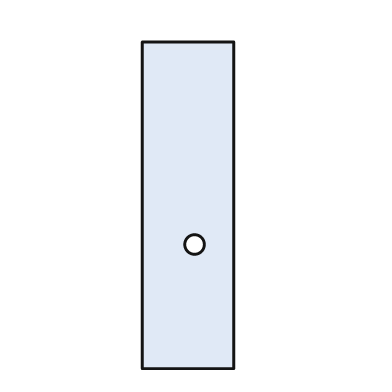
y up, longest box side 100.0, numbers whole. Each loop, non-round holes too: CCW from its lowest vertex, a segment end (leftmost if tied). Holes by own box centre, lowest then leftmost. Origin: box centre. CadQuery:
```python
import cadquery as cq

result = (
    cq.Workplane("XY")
    .moveTo(-14.0, -50.0)
    .lineTo(14.0, -50.0)
    .lineTo(14.0, 50.0)
    .lineTo(-14.0, 50.0)
    .close()
    .moveTo(2.0, -12.0)
    .circle(3.0)
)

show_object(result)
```